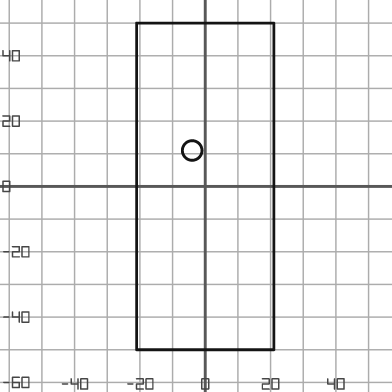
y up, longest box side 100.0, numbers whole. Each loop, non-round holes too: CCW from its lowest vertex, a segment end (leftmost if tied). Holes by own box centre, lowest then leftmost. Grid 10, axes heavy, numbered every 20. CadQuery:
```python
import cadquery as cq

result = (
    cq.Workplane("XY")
    .moveTo(-21.0, -50.0)
    .lineTo(21.0, -50.0)
    .lineTo(21.0, 50.0)
    .lineTo(-21.0, 50.0)
    .close()
    .moveTo(-4.0, 11.0)
    .circle(3.0)
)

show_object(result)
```